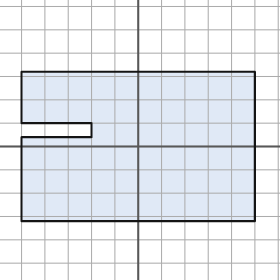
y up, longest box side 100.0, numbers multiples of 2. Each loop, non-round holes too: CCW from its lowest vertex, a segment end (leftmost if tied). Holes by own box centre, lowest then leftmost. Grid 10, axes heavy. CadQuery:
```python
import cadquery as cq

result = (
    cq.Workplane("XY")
    .moveTo(-50.0, -32.0)
    .lineTo(50.0, -32.0)
    .lineTo(50.0, 32.0)
    .lineTo(-50.0, 32.0)
    .lineTo(-50.0, 10.0)
    .lineTo(-20.0, 10.0)
    .lineTo(-20.0, 4.0)
    .lineTo(-50.0, 4.0)
    .close()
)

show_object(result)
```